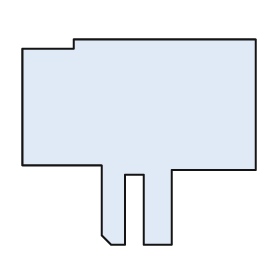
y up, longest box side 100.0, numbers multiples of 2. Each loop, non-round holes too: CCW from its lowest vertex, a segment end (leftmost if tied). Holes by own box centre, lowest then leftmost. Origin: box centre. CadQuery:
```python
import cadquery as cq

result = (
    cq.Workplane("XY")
    .moveTo(-12.0, -44.0)
    .lineTo(-6.0, -44.0)
    .lineTo(-6.0, -14.0)
    .lineTo(2.0, -14.0)
    .lineTo(2.0, -44.0)
    .lineTo(14.0, -44.0)
    .lineTo(14.0, -12.0)
    .lineTo(50.0, -12.0)
    .lineTo(50.0, 44.0)
    .lineTo(-28.0, 44.0)
    .lineTo(-28.0, 40.0)
    .lineTo(-50.0, 40.0)
    .lineTo(-50.0, -10.0)
    .lineTo(-16.0, -10.0)
    .lineTo(-16.0, -40.0)
    .close()
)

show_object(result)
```